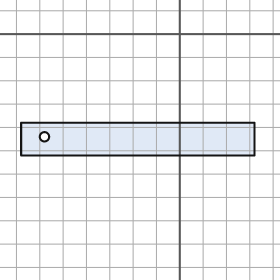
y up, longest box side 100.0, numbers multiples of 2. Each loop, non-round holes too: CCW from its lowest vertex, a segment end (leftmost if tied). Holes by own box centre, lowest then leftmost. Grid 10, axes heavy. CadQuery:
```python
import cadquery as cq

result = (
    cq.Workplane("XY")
    .moveTo(-68.0, -52.0)
    .lineTo(32.0, -52.0)
    .lineTo(32.0, -38.0)
    .lineTo(-68.0, -38.0)
    .close()
    .moveTo(-58.0, -44.0)
    .circle(2.0)
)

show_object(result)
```